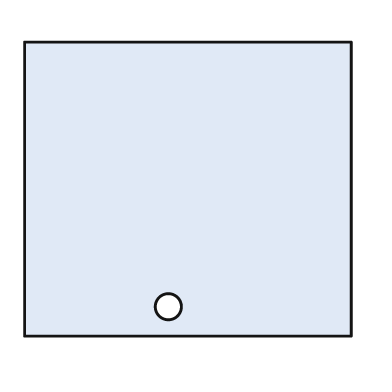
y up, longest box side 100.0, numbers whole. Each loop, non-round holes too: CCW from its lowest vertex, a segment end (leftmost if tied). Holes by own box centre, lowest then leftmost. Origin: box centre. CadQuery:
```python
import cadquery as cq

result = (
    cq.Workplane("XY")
    .moveTo(-50.0, -45.0)
    .lineTo(50.0, -45.0)
    .lineTo(50.0, 45.0)
    .lineTo(-50.0, 45.0)
    .close()
    .moveTo(-6.0, -36.0)
    .circle(4.0)
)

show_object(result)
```